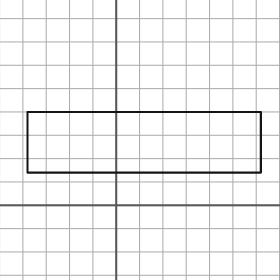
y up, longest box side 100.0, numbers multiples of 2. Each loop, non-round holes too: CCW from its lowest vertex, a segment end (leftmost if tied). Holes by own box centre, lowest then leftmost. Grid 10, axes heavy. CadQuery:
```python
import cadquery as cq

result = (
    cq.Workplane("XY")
    .moveTo(-38.0, 14.0)
    .lineTo(62.0, 14.0)
    .lineTo(62.0, 40.0)
    .lineTo(-38.0, 40.0)
    .close()
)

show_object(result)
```